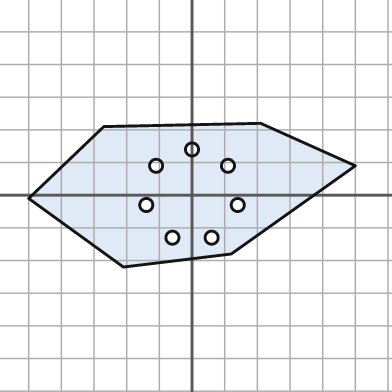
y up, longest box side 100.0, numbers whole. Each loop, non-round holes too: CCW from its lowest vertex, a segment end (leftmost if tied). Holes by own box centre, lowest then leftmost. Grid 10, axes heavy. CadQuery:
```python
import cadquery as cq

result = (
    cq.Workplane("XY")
    .moveTo(-21.0, -22.0)
    .lineTo(12.0, -18.0)
    .lineTo(50.0, 9.0)
    .lineTo(21.0, 22.0)
    .lineTo(-27.0, 21.0)
    .lineTo(-50.0, -1.0)
    .close()
    .moveTo(-6.0, -13.0)
    .circle(2.0)
    .moveTo(6.0, -13.0)
    .circle(2.0)
    .moveTo(-14.0, -3.0)
    .circle(2.0)
    .moveTo(14.0, -3.0)
    .circle(2.0)
    .moveTo(-11.0, 9.0)
    .circle(2.0)
    .moveTo(11.0, 9.0)
    .circle(2.0)
    .moveTo(0.0, 14.0)
    .circle(2.0)
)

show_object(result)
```